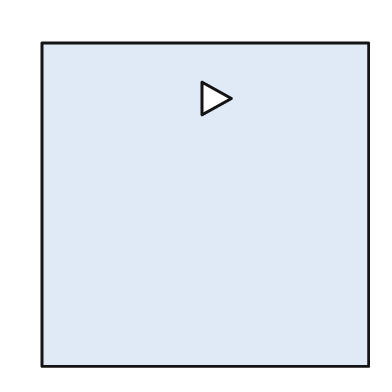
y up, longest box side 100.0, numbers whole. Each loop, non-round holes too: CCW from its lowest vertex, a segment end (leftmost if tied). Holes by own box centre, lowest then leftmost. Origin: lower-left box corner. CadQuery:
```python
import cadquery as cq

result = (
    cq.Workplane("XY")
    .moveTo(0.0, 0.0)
    .lineTo(100.0, 0.0)
    .lineTo(100.0, 99.0)
    .lineTo(0.0, 99.0)
    .close()
    .moveTo(49.0, 77.0)
    .lineTo(58.0, 82.0)
    .lineTo(49.0, 87.0)
    .close()
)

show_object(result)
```